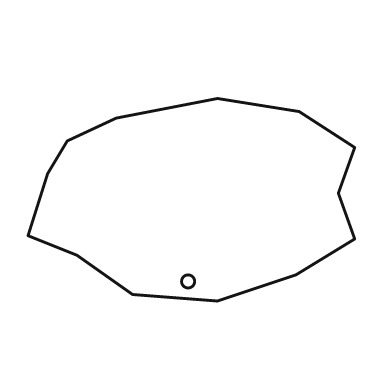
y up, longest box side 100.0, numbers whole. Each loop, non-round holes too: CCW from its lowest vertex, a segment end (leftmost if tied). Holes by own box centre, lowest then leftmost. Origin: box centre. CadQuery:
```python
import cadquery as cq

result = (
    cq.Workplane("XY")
    .moveTo(8.0, -31.0)
    .lineTo(32.0, -23.0)
    .lineTo(50.0, -12.0)
    .lineTo(45.0, 2.0)
    .lineTo(50.0, 16.0)
    .lineTo(33.0, 27.0)
    .lineTo(8.0, 31.0)
    .lineTo(-23.0, 25.0)
    .lineTo(-38.0, 18.0)
    .lineTo(-44.0, 8.0)
    .lineTo(-50.0, -11.0)
    .lineTo(-35.0, -17.0)
    .lineTo(-18.0, -29.0)
    .close()
    .moveTo(-1.0, -25.0)
    .circle(2.0)
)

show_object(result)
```